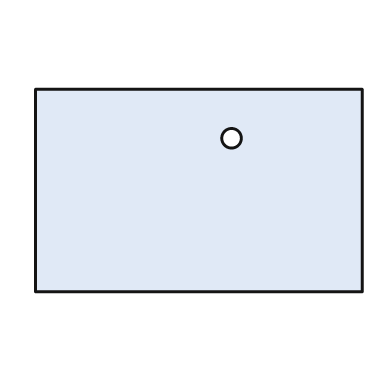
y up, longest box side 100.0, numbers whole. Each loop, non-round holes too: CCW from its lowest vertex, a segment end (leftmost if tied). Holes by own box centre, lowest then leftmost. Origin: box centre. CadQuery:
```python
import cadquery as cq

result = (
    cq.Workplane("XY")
    .moveTo(-50.0, -31.0)
    .lineTo(50.0, -31.0)
    .lineTo(50.0, 31.0)
    .lineTo(-50.0, 31.0)
    .close()
    .moveTo(10.0, 16.0)
    .circle(3.0)
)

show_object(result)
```